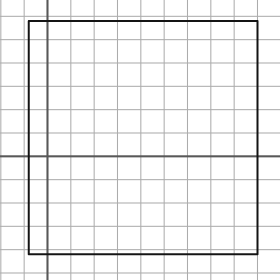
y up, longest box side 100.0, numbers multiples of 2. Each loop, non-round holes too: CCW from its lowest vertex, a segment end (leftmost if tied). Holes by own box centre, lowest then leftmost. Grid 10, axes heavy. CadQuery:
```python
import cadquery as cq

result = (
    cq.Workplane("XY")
    .moveTo(-8.0, -42.0)
    .lineTo(90.0, -42.0)
    .lineTo(90.0, 58.0)
    .lineTo(-8.0, 58.0)
    .close()
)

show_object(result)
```